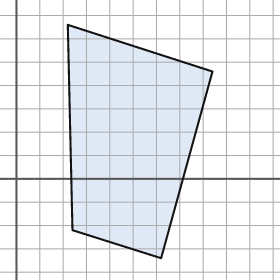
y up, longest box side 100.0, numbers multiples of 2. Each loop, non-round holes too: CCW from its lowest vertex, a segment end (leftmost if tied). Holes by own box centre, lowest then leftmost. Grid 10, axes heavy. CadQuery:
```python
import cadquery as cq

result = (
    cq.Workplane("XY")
    .moveTo(62.0, -34.0)
    .lineTo(84.0, 46.0)
    .lineTo(22.0, 66.0)
    .lineTo(24.0, -22.0)
    .close()
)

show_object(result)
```